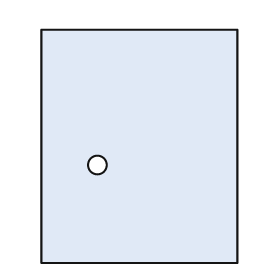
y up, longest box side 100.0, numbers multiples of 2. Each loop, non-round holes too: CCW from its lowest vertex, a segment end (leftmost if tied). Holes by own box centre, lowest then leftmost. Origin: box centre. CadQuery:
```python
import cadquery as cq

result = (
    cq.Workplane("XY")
    .moveTo(-42.0, -50.0)
    .lineTo(42.0, -50.0)
    .lineTo(42.0, 50.0)
    .lineTo(-42.0, 50.0)
    .close()
    .moveTo(-18.0, -8.0)
    .circle(4.0)
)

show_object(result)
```